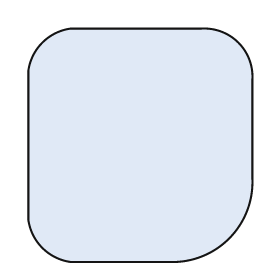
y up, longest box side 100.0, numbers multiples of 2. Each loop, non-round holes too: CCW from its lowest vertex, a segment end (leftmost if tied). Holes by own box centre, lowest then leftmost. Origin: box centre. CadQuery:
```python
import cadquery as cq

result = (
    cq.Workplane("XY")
    .moveTo(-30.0, -50.0)
    .lineTo(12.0, -50.0)
    .threePointArc((38.0, -40.0), (48.0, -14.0))
    .lineTo(48.0, 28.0)
    .threePointArc((42.0, 44.0), (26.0, 50.0))
    .lineTo(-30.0, 50.0)
    .threePointArc((-42.0, 44.0), (-48.0, 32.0))
    .lineTo(-48.0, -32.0)
    .threePointArc((-42.0, -44.0), (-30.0, -50.0))
    .close()
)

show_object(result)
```